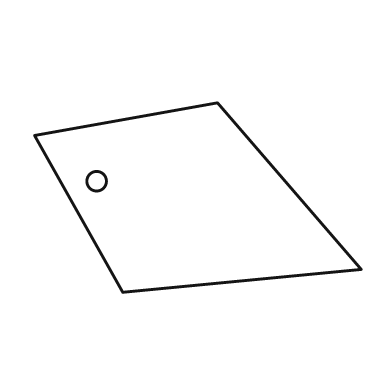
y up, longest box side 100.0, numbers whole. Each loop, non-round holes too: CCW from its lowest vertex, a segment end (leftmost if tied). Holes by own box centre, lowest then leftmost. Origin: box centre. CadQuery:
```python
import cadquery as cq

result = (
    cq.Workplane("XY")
    .moveTo(-23.0, -29.0)
    .lineTo(50.0, -22.0)
    .lineTo(6.0, 29.0)
    .lineTo(-50.0, 19.0)
    .close()
    .moveTo(-31.0, 5.0)
    .circle(3.0)
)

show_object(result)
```